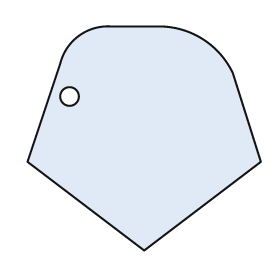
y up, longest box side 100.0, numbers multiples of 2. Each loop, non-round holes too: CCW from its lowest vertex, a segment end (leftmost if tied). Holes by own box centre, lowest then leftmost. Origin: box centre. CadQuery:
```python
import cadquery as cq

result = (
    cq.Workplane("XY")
    .moveTo(0.0, -48.0)
    .lineTo(50.0, -10.0)
    .lineTo(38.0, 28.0)
    .threePointArc((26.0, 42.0), (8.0, 48.0))
    .lineTo(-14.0, 48.0)
    .threePointArc((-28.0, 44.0), (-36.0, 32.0))
    .lineTo(-50.0, -10.0)
    .close()
    .moveTo(-32.0, 18.0)
    .circle(4.0)
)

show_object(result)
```